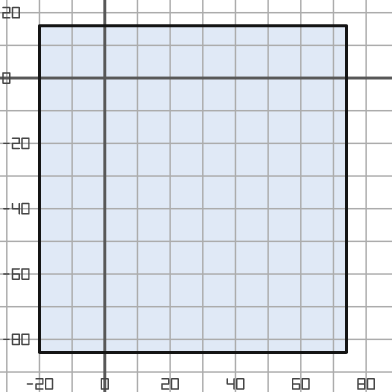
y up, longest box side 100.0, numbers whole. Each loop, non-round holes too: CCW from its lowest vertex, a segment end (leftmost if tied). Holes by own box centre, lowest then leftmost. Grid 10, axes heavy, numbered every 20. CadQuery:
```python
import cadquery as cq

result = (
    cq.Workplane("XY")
    .moveTo(-20.0, -84.0)
    .lineTo(74.0, -84.0)
    .lineTo(74.0, 16.0)
    .lineTo(-20.0, 16.0)
    .close()
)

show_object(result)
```